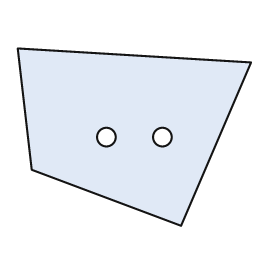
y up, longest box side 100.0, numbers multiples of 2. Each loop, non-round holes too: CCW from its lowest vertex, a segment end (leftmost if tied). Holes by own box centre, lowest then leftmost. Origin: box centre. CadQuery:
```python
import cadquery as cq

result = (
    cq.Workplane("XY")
    .moveTo(20.0, -38.0)
    .lineTo(50.0, 32.0)
    .lineTo(-50.0, 38.0)
    .lineTo(-44.0, -14.0)
    .close()
    .moveTo(-12.0, 0.0)
    .circle(4.0)
    .moveTo(12.0, 0.0)
    .circle(4.0)
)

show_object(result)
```